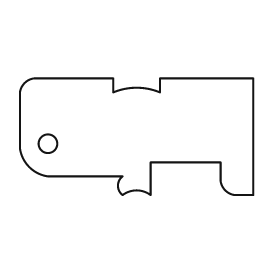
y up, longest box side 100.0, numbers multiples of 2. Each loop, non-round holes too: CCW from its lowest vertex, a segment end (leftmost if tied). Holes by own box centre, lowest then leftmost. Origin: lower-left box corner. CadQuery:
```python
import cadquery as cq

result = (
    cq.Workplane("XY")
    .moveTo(44.0, 0.0)
    .threePointArc((50.0, 2.0), (56.0, 0.0))
    .lineTo(56.0, 14.0)
    .lineTo(86.0, 14.0)
    .lineTo(86.0, 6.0)
    .threePointArc((88.0, 2.0), (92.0, 0.0))
    .lineTo(100.0, 0.0)
    .lineTo(100.0, 50.0)
    .lineTo(60.0, 50.0)
    .lineTo(60.0, 44.0)
    .threePointArc((50.0, 46.0), (40.0, 44.0))
    .lineTo(40.0, 50.0)
    .lineTo(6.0, 50.0)
    .threePointArc((2.0, 48.0), (0.0, 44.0))
    .lineTo(0.0, 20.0)
    .threePointArc((4.0, 12.0), (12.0, 8.0))
    .lineTo(44.0, 8.0)
    .threePointArc((42.0, 4.0), (44.0, 0.0))
    .close()
    .moveTo(12.0, 22.0)
    .circle(4.0)
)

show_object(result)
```